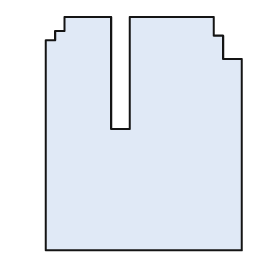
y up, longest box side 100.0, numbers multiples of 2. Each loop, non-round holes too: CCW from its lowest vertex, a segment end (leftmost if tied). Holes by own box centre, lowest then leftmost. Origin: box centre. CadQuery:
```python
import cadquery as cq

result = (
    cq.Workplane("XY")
    .moveTo(-42.0, -50.0)
    .lineTo(42.0, -50.0)
    .lineTo(42.0, 32.0)
    .lineTo(34.0, 32.0)
    .lineTo(34.0, 42.0)
    .lineTo(30.0, 42.0)
    .lineTo(30.0, 50.0)
    .lineTo(-6.0, 50.0)
    .lineTo(-6.0, 2.0)
    .lineTo(-14.0, 2.0)
    .lineTo(-14.0, 50.0)
    .lineTo(-34.0, 50.0)
    .lineTo(-34.0, 44.0)
    .lineTo(-38.0, 44.0)
    .lineTo(-38.0, 40.0)
    .lineTo(-42.0, 40.0)
    .close()
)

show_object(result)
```